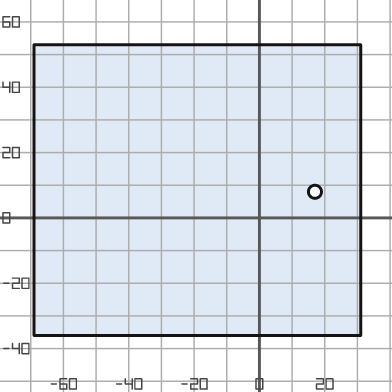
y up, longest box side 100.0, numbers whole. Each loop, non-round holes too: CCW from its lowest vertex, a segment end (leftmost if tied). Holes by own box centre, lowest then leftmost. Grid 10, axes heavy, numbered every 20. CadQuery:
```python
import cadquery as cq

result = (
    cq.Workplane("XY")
    .moveTo(-69.0, -36.0)
    .lineTo(31.0, -36.0)
    .lineTo(31.0, 53.0)
    .lineTo(-69.0, 53.0)
    .close()
    .moveTo(17.0, 8.0)
    .circle(2.0)
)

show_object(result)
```